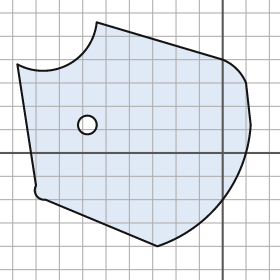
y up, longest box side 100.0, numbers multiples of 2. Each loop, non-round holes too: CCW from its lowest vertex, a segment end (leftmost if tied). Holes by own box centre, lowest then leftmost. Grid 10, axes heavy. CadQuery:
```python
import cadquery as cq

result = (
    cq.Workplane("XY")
    .moveTo(-28.0, -40.0)
    .threePointArc((0.0, -20.0), (12.0, 12.0))
    .lineTo(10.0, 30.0)
    .threePointArc((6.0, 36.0), (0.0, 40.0))
    .lineTo(-54.0, 56.0)
    .threePointArc((-66.0, 38.0), (-88.0, 38.0))
    .lineTo(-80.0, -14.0)
    .threePointArc((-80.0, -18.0), (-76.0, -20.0))
    .close()
    .moveTo(-58.0, 12.0)
    .circle(4.0)
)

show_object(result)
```